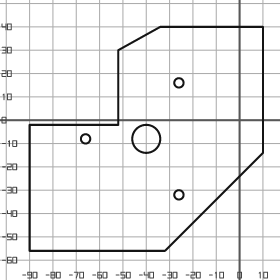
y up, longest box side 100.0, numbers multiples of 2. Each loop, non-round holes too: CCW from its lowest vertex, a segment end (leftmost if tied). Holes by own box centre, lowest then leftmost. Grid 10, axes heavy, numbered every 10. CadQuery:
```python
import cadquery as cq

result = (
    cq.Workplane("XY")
    .moveTo(-90.0, -56.0)
    .lineTo(-32.0, -56.0)
    .lineTo(10.0, -14.0)
    .lineTo(10.0, 40.0)
    .lineTo(-34.0, 40.0)
    .lineTo(-52.0, 30.0)
    .lineTo(-52.0, -2.0)
    .lineTo(-90.0, -2.0)
    .close()
    .moveTo(-26.0, -32.0)
    .circle(2.0)
    .moveTo(-66.0, -8.0)
    .circle(2.0)
    .moveTo(-40.0, -8.0)
    .circle(6.0)
    .moveTo(-26.0, 16.0)
    .circle(2.0)
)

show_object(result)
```